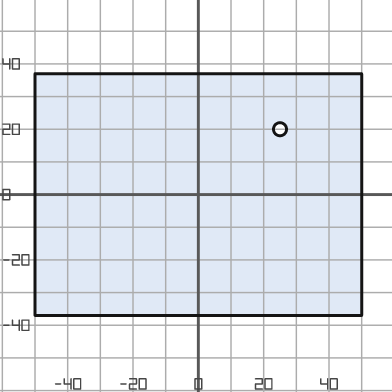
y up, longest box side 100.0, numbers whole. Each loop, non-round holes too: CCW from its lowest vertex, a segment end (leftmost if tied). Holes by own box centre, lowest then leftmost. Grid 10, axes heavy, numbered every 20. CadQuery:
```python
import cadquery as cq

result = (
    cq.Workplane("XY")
    .moveTo(-50.0, -37.0)
    .lineTo(50.0, -37.0)
    .lineTo(50.0, 37.0)
    .lineTo(-50.0, 37.0)
    .close()
    .moveTo(25.0, 20.0)
    .circle(2.0)
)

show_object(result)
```